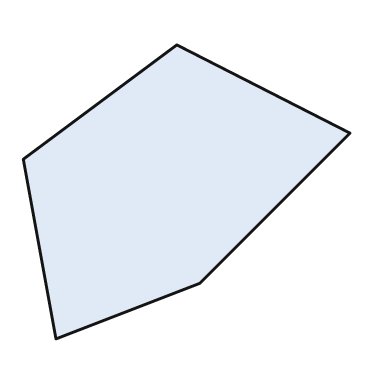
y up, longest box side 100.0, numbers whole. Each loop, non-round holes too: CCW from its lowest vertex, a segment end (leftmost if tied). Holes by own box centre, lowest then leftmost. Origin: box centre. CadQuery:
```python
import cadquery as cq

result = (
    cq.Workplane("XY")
    .moveTo(-40.0, -45.0)
    .lineTo(4.0, -28.0)
    .lineTo(50.0, 18.0)
    .lineTo(-3.0, 45.0)
    .lineTo(-50.0, 10.0)
    .close()
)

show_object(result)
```